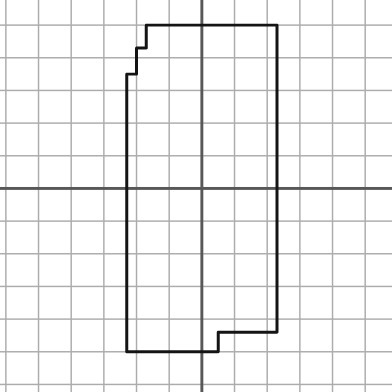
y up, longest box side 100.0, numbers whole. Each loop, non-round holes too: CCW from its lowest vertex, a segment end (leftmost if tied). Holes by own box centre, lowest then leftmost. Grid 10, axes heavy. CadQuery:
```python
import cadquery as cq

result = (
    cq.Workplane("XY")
    .moveTo(-23.0, -50.0)
    .lineTo(5.0, -50.0)
    .lineTo(5.0, -44.0)
    .lineTo(23.0, -44.0)
    .lineTo(23.0, 50.0)
    .lineTo(-17.0, 50.0)
    .lineTo(-17.0, 43.0)
    .lineTo(-20.0, 43.0)
    .lineTo(-20.0, 35.0)
    .lineTo(-23.0, 35.0)
    .close()
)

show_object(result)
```